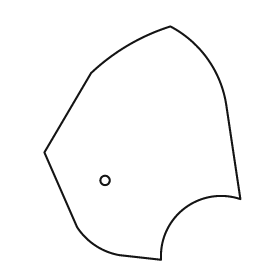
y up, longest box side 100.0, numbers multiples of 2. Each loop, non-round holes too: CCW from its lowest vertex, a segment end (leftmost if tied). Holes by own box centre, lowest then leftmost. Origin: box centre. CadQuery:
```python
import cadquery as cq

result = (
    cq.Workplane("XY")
    .moveTo(8.0, -50.0)
    .threePointArc((18.0, -28.0), (42.0, -24.0))
    .lineTo(36.0, 16.0)
    .threePointArc((28.0, 36.0), (12.0, 50.0))
    .threePointArc((-6.0, 42.0), (-22.0, 30.0))
    .lineTo(-42.0, -4.0)
    .lineTo(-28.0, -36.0)
    .threePointArc((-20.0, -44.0), (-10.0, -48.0))
    .close()
    .moveTo(-16.0, -16.0)
    .circle(2.0)
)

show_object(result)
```